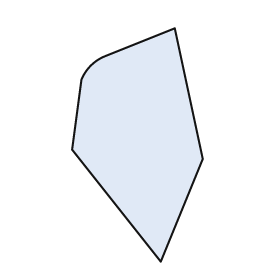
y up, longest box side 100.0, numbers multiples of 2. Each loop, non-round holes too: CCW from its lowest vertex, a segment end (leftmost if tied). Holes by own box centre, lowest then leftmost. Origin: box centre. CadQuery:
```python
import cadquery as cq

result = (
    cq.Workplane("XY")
    .moveTo(10.0, -50.0)
    .lineTo(28.0, -6.0)
    .lineTo(16.0, 50.0)
    .lineTo(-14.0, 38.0)
    .threePointArc((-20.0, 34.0), (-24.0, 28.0))
    .lineTo(-28.0, -2.0)
    .close()
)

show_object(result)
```